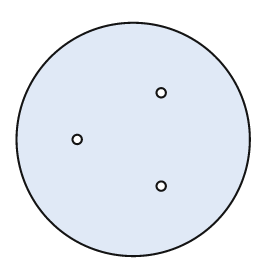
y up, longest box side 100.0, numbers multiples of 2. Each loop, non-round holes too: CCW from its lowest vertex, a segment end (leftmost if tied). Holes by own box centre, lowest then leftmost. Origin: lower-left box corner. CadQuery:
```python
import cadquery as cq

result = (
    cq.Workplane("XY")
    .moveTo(50.0, 50.0)
    .circle(50.0)
    .moveTo(62.0, 30.0)
    .circle(2.0)
    .moveTo(26.0, 50.0)
    .circle(2.0)
    .moveTo(62.0, 70.0)
    .circle(2.0)
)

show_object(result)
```